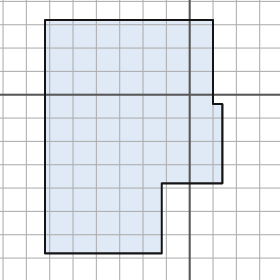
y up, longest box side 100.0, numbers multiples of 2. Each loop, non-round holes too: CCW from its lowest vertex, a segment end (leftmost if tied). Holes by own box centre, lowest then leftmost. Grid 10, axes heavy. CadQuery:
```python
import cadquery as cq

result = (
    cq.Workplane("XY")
    .moveTo(-62.0, -68.0)
    .lineTo(-12.0, -68.0)
    .lineTo(-12.0, -38.0)
    .lineTo(14.0, -38.0)
    .lineTo(14.0, -4.0)
    .lineTo(10.0, -4.0)
    .lineTo(10.0, 32.0)
    .lineTo(-62.0, 32.0)
    .close()
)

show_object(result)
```